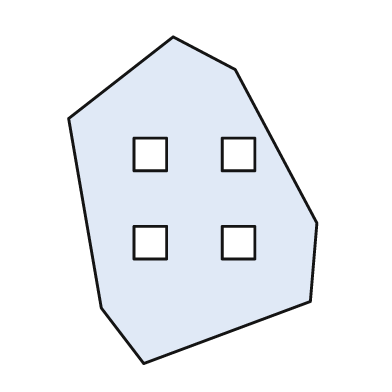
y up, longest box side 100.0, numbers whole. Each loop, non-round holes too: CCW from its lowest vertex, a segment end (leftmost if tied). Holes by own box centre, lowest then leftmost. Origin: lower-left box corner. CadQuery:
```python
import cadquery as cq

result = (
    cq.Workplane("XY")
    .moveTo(23.0, 0.0)
    .lineTo(74.0, 19.0)
    .lineTo(76.0, 43.0)
    .lineTo(51.0, 90.0)
    .lineTo(32.0, 100.0)
    .lineTo(0.0, 75.0)
    .lineTo(10.0, 17.0)
    .close()
    .moveTo(20.0, 32.0)
    .lineTo(30.0, 32.0)
    .lineTo(30.0, 42.0)
    .lineTo(20.0, 42.0)
    .close()
    .moveTo(47.0, 32.0)
    .lineTo(57.0, 32.0)
    .lineTo(57.0, 42.0)
    .lineTo(47.0, 42.0)
    .close()
    .moveTo(20.0, 59.0)
    .lineTo(30.0, 59.0)
    .lineTo(30.0, 69.0)
    .lineTo(20.0, 69.0)
    .close()
    .moveTo(47.0, 59.0)
    .lineTo(57.0, 59.0)
    .lineTo(57.0, 69.0)
    .lineTo(47.0, 69.0)
    .close()
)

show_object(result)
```